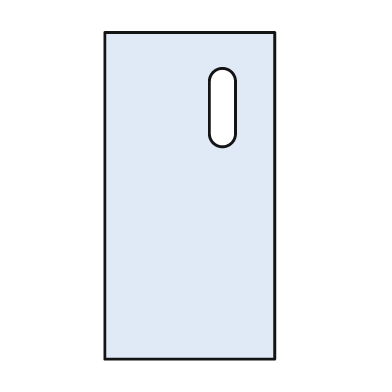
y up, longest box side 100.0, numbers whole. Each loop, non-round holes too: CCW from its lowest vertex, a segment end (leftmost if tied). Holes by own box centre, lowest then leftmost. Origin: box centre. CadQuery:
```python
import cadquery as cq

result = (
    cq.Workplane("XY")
    .moveTo(-26.0, -50.0)
    .lineTo(26.0, -50.0)
    .lineTo(26.0, 50.0)
    .lineTo(-26.0, 50.0)
    .close()
    .moveTo(6.0, 19.0)
    .threePointArc((10.0, 15.0), (14.0, 19.0))
    .lineTo(14.0, 35.0)
    .threePointArc((10.0, 39.0), (6.0, 35.0))
    .close()
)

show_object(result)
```